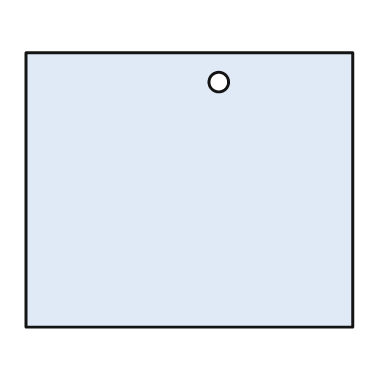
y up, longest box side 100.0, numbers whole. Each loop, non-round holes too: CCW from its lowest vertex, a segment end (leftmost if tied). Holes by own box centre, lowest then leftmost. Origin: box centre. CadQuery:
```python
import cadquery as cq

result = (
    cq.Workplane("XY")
    .moveTo(-50.0, -42.0)
    .lineTo(50.0, -42.0)
    .lineTo(50.0, 42.0)
    .lineTo(-50.0, 42.0)
    .close()
    .moveTo(9.0, 33.0)
    .circle(3.0)
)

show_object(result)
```